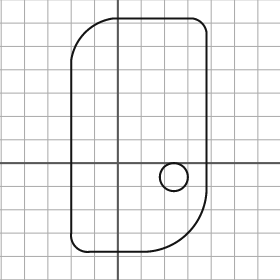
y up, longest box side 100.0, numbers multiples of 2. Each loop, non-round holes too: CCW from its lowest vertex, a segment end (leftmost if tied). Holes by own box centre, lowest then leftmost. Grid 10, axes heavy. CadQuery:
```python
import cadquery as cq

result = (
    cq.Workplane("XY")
    .moveTo(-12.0, -38.0)
    .lineTo(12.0, -38.0)
    .threePointArc((30.0, -30.0), (38.0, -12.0))
    .lineTo(38.0, 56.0)
    .threePointArc((36.0, 60.0), (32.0, 62.0))
    .lineTo(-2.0, 62.0)
    .threePointArc((-14.0, 56.0), (-20.0, 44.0))
    .lineTo(-20.0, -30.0)
    .threePointArc((-18.0, -36.0), (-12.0, -38.0))
    .close()
    .moveTo(24.0, -6.0)
    .circle(6.0)
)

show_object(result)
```